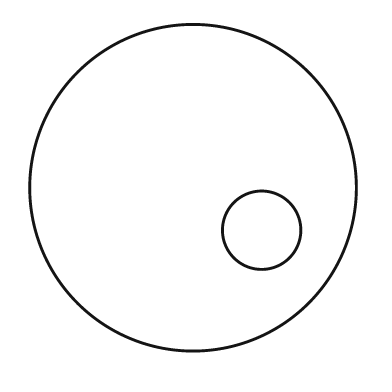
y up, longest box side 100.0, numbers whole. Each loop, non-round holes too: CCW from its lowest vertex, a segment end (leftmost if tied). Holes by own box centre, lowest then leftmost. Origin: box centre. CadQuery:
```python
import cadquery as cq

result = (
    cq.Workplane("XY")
    .moveTo(0.0, 0.0)
    .circle(50.0)
    .moveTo(21.0, -13.0)
    .circle(12.0)
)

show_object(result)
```